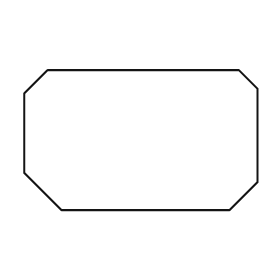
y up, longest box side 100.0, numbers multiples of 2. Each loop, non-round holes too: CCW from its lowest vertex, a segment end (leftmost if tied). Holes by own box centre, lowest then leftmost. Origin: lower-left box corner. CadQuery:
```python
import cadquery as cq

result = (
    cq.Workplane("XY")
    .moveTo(16.0, 0.0)
    .lineTo(88.0, 0.0)
    .lineTo(100.0, 12.0)
    .lineTo(100.0, 52.0)
    .lineTo(92.0, 60.0)
    .lineTo(10.0, 60.0)
    .lineTo(0.0, 50.0)
    .lineTo(0.0, 16.0)
    .close()
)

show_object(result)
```